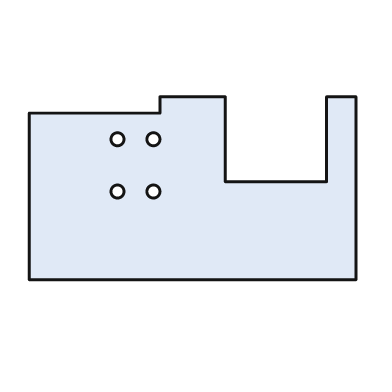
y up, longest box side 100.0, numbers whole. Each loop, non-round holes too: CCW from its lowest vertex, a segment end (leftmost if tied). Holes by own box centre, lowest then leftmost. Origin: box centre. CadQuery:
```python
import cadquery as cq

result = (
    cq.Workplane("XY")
    .moveTo(-50.0, -28.0)
    .lineTo(50.0, -28.0)
    .lineTo(50.0, 28.0)
    .lineTo(41.0, 28.0)
    .lineTo(41.0, 2.0)
    .lineTo(10.0, 2.0)
    .lineTo(10.0, 28.0)
    .lineTo(-10.0, 28.0)
    .lineTo(-10.0, 23.0)
    .lineTo(-50.0, 23.0)
    .close()
    .moveTo(-23.0, -1.0)
    .circle(2.0)
    .moveTo(-12.0, -1.0)
    .circle(2.0)
    .moveTo(-23.0, 15.0)
    .circle(2.0)
    .moveTo(-12.0, 15.0)
    .circle(2.0)
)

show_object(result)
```